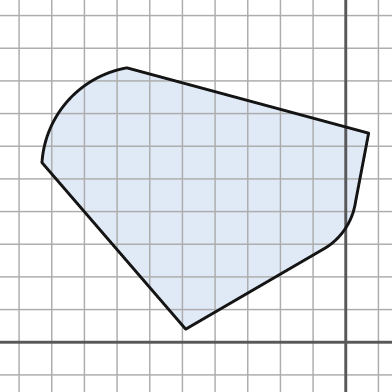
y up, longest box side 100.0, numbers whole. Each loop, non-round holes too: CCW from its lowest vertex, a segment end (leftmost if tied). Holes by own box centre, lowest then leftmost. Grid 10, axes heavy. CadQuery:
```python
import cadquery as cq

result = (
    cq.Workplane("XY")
    .moveTo(-49.0, 4.0)
    .lineTo(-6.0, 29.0)
    .threePointArc((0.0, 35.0), (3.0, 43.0))
    .lineTo(7.0, 64.0)
    .lineTo(-67.0, 84.0)
    .threePointArc((-85.0, 74.0), (-93.0, 55.0))
    .close()
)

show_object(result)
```